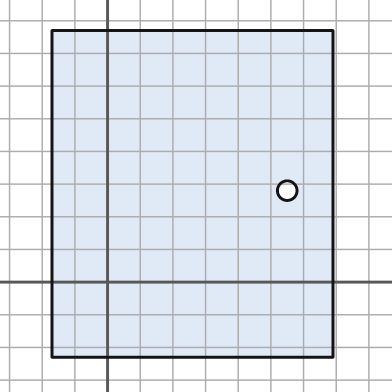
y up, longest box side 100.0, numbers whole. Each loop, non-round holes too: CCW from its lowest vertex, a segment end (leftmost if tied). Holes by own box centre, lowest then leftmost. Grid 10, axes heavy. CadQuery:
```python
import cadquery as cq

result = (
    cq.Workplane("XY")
    .moveTo(-17.0, -23.0)
    .lineTo(69.0, -23.0)
    .lineTo(69.0, 77.0)
    .lineTo(-17.0, 77.0)
    .close()
    .moveTo(55.0, 28.0)
    .circle(3.0)
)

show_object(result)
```